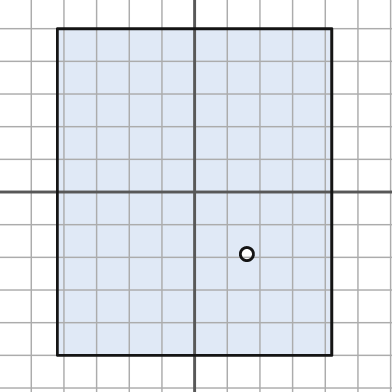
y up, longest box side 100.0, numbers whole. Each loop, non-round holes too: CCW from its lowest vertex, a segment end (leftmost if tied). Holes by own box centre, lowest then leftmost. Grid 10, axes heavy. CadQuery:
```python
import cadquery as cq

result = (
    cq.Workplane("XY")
    .moveTo(-42.0, -50.0)
    .lineTo(42.0, -50.0)
    .lineTo(42.0, 50.0)
    .lineTo(-42.0, 50.0)
    .close()
    .moveTo(16.0, -19.0)
    .circle(2.0)
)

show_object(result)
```